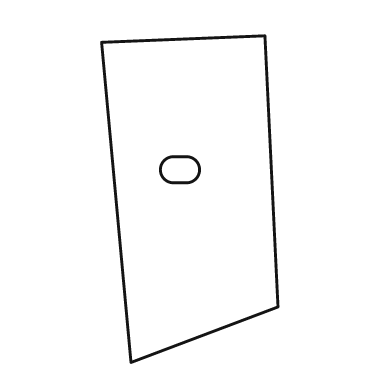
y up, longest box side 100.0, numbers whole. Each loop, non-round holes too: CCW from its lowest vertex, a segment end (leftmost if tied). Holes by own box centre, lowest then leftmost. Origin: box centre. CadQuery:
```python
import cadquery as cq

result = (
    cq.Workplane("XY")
    .moveTo(-18.0, -50.0)
    .lineTo(27.0, -33.0)
    .lineTo(23.0, 50.0)
    .lineTo(-27.0, 48.0)
    .close()
    .moveTo(-5.0, 5.0)
    .lineTo(-1.0, 5.0)
    .threePointArc((3.0, 9.0), (-1.0, 13.0))
    .lineTo(-5.0, 13.0)
    .threePointArc((-9.0, 9.0), (-5.0, 5.0))
    .close()
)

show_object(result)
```